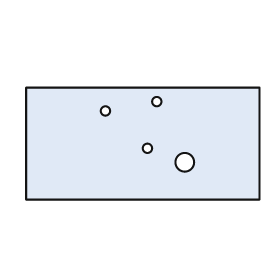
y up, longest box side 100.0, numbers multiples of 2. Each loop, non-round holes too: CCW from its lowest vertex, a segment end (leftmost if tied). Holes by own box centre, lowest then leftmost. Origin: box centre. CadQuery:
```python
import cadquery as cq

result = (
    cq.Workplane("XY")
    .moveTo(-50.0, -24.0)
    .lineTo(50.0, -24.0)
    .lineTo(50.0, 24.0)
    .lineTo(-50.0, 24.0)
    .close()
    .moveTo(18.0, -8.0)
    .circle(4.0)
    .moveTo(2.0, -2.0)
    .circle(2.0)
    .moveTo(-16.0, 14.0)
    .circle(2.0)
    .moveTo(6.0, 18.0)
    .circle(2.0)
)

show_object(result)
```